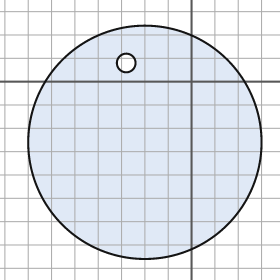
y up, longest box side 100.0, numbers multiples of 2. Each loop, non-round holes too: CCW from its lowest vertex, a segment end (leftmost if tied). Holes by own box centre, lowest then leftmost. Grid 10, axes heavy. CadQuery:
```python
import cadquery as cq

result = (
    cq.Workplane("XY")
    .moveTo(-20.0, -26.0)
    .circle(50.0)
    .moveTo(-28.0, 8.0)
    .circle(4.0)
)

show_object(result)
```